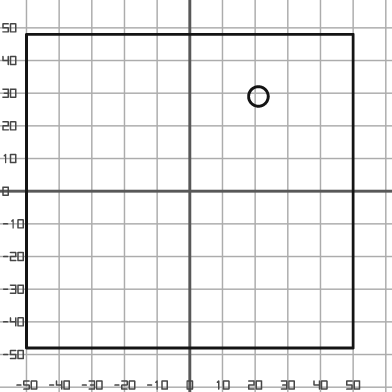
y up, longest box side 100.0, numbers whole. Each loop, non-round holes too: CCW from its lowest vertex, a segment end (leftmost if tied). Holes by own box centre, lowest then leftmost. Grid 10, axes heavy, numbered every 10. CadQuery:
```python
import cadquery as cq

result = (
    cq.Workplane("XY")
    .moveTo(-50.0, -48.0)
    .lineTo(50.0, -48.0)
    .lineTo(50.0, 48.0)
    .lineTo(-50.0, 48.0)
    .close()
    .moveTo(21.0, 29.0)
    .circle(3.0)
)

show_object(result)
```